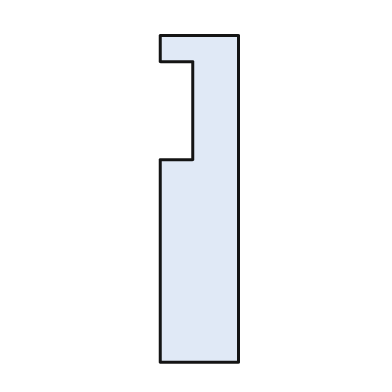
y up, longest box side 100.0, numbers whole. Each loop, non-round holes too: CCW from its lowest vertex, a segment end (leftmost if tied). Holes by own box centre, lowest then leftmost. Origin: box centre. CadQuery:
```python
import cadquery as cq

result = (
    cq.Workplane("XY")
    .moveTo(-12.0, -50.0)
    .lineTo(12.0, -50.0)
    .lineTo(12.0, 50.0)
    .lineTo(-12.0, 50.0)
    .lineTo(-12.0, 42.0)
    .lineTo(-2.0, 42.0)
    .lineTo(-2.0, 12.0)
    .lineTo(-12.0, 12.0)
    .close()
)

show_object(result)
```